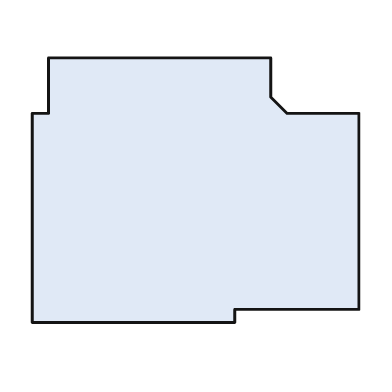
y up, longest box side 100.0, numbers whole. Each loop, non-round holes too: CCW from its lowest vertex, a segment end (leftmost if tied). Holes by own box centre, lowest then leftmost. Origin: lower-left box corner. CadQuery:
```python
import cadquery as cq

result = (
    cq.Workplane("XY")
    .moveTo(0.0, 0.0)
    .lineTo(62.0, 0.0)
    .lineTo(62.0, 4.0)
    .lineTo(100.0, 4.0)
    .lineTo(100.0, 64.0)
    .lineTo(78.0, 64.0)
    .lineTo(73.0, 69.0)
    .lineTo(73.0, 81.0)
    .lineTo(5.0, 81.0)
    .lineTo(5.0, 64.0)
    .lineTo(0.0, 64.0)
    .close()
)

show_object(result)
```